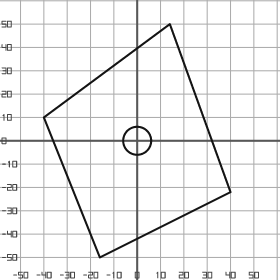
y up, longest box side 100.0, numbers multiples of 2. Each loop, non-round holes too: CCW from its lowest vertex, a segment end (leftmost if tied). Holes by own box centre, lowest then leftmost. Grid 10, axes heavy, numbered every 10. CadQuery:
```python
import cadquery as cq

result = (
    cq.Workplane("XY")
    .moveTo(-16.0, -50.0)
    .lineTo(40.0, -22.0)
    .lineTo(14.0, 50.0)
    .lineTo(-40.0, 10.0)
    .close()
    .moveTo(0.0, 0.0)
    .circle(6.0)
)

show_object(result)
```